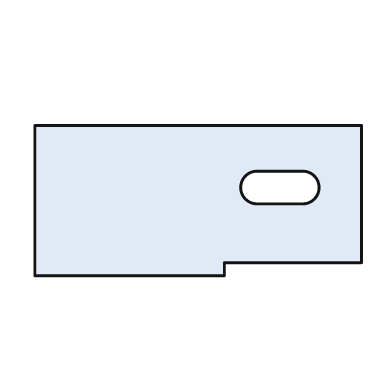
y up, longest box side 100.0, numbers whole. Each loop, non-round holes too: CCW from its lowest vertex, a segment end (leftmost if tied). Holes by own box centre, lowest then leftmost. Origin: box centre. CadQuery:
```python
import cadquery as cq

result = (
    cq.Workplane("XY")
    .moveTo(-50.0, -23.0)
    .lineTo(8.0, -23.0)
    .lineTo(8.0, -19.0)
    .lineTo(50.0, -19.0)
    .lineTo(50.0, 23.0)
    .lineTo(-50.0, 23.0)
    .close()
    .moveTo(18.0, -1.0)
    .lineTo(32.0, -1.0)
    .threePointArc((37.0, 4.0), (32.0, 9.0))
    .lineTo(18.0, 9.0)
    .threePointArc((13.0, 4.0), (18.0, -1.0))
    .close()
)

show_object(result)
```